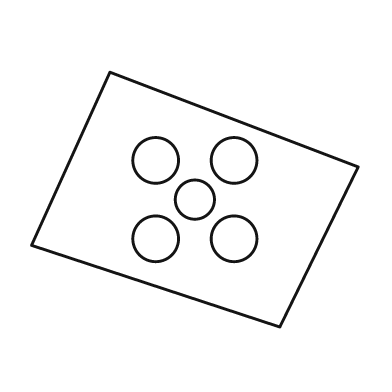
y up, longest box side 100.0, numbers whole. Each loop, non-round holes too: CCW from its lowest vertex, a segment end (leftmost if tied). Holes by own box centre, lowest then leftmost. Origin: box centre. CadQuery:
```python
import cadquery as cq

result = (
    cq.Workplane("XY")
    .moveTo(26.0, -39.0)
    .lineTo(50.0, 10.0)
    .lineTo(-26.0, 39.0)
    .lineTo(-50.0, -14.0)
    .close()
    .moveTo(-12.0, -12.0)
    .circle(7.0)
    .moveTo(12.0, -12.0)
    .circle(7.0)
    .moveTo(0.0, 0.0)
    .circle(6.0)
    .moveTo(-12.0, 12.0)
    .circle(7.0)
    .moveTo(12.0, 12.0)
    .circle(7.0)
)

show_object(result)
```